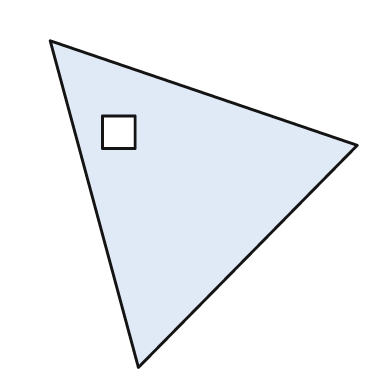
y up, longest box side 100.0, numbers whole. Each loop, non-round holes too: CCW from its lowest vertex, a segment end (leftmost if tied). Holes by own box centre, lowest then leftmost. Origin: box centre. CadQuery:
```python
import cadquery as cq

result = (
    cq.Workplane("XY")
    .moveTo(-20.0, -50.0)
    .lineTo(47.0, 18.0)
    .lineTo(-47.0, 50.0)
    .close()
    .moveTo(-31.0, 17.0)
    .lineTo(-21.0, 17.0)
    .lineTo(-21.0, 27.0)
    .lineTo(-31.0, 27.0)
    .close()
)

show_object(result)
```